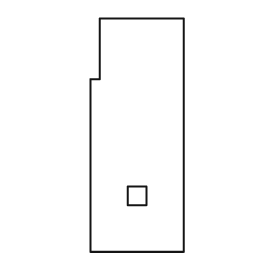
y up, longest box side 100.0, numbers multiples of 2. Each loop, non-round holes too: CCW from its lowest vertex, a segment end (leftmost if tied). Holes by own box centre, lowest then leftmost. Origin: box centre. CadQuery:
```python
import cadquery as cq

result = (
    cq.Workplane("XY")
    .moveTo(-20.0, -50.0)
    .lineTo(20.0, -50.0)
    .lineTo(20.0, 50.0)
    .lineTo(-16.0, 50.0)
    .lineTo(-16.0, 24.0)
    .lineTo(-20.0, 24.0)
    .close()
    .moveTo(-4.0, -30.0)
    .lineTo(4.0, -30.0)
    .lineTo(4.0, -22.0)
    .lineTo(-4.0, -22.0)
    .close()
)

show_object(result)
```